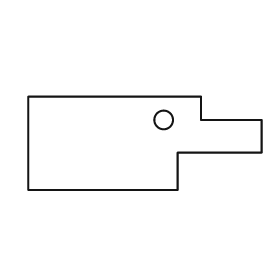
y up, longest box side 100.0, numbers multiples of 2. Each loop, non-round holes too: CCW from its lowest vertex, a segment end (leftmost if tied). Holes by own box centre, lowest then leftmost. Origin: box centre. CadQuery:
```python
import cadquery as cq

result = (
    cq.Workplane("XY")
    .moveTo(-50.0, -20.0)
    .lineTo(14.0, -20.0)
    .lineTo(14.0, -4.0)
    .lineTo(50.0, -4.0)
    .lineTo(50.0, 10.0)
    .lineTo(24.0, 10.0)
    .lineTo(24.0, 20.0)
    .lineTo(-50.0, 20.0)
    .close()
    .moveTo(8.0, 10.0)
    .circle(4.0)
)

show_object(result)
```